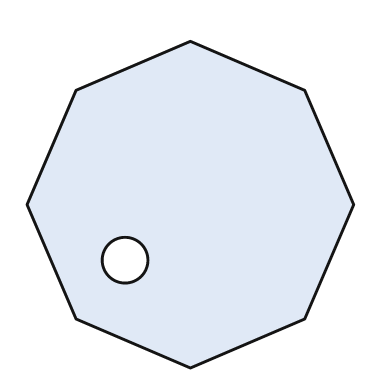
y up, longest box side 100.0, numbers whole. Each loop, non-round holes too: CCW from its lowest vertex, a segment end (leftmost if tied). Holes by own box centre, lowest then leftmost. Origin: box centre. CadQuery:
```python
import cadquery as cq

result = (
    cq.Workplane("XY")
    .moveTo(0.0, -50.0)
    .lineTo(35.0, -35.0)
    .lineTo(50.0, 0.0)
    .lineTo(35.0, 35.0)
    .lineTo(0.0, 50.0)
    .lineTo(-35.0, 35.0)
    .lineTo(-50.0, 0.0)
    .lineTo(-35.0, -35.0)
    .close()
    .moveTo(-20.0, -17.0)
    .circle(7.0)
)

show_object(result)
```